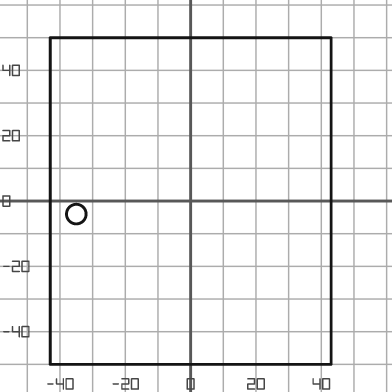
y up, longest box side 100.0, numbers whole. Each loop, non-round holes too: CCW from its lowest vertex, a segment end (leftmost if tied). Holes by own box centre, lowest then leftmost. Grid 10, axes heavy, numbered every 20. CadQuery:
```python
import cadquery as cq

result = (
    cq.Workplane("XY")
    .moveTo(-43.0, -50.0)
    .lineTo(43.0, -50.0)
    .lineTo(43.0, 50.0)
    .lineTo(-43.0, 50.0)
    .close()
    .moveTo(-35.0, -4.0)
    .circle(3.0)
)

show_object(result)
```